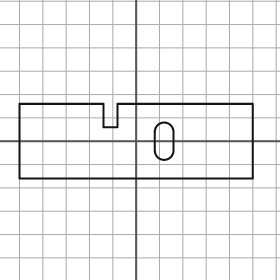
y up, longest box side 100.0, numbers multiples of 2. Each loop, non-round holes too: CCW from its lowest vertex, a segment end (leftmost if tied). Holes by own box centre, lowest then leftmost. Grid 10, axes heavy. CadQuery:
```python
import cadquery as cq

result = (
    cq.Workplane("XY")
    .moveTo(-50.0, -16.0)
    .lineTo(50.0, -16.0)
    .lineTo(50.0, 16.0)
    .lineTo(-8.0, 16.0)
    .lineTo(-8.0, 6.0)
    .lineTo(-14.0, 6.0)
    .lineTo(-14.0, 16.0)
    .lineTo(-50.0, 16.0)
    .close()
    .moveTo(8.0, -4.0)
    .threePointArc((12.0, -8.0), (16.0, -4.0))
    .lineTo(16.0, 4.0)
    .threePointArc((12.0, 8.0), (8.0, 4.0))
    .close()
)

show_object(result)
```